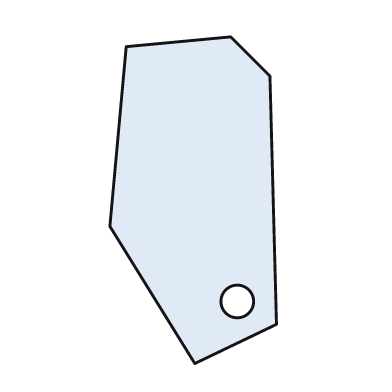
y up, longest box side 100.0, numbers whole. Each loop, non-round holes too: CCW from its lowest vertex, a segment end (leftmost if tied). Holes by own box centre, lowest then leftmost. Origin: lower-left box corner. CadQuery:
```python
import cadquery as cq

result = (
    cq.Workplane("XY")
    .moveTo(26.0, 0.0)
    .lineTo(51.0, 12.0)
    .lineTo(49.0, 88.0)
    .lineTo(37.0, 100.0)
    .lineTo(5.0, 97.0)
    .lineTo(0.0, 42.0)
    .close()
    .moveTo(39.0, 19.0)
    .circle(5.0)
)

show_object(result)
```